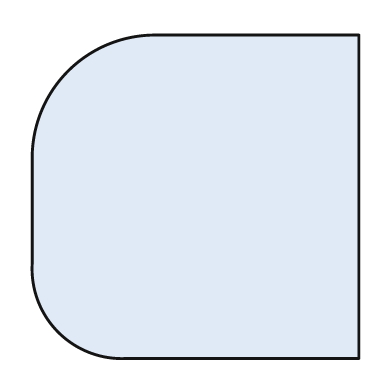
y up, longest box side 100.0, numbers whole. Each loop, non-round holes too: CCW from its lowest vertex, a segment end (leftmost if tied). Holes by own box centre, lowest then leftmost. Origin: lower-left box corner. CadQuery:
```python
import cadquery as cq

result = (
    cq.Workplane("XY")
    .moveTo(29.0, 0.0)
    .lineTo(100.0, 0.0)
    .lineTo(100.0, 99.0)
    .lineTo(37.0, 99.0)
    .threePointArc((11.0, 88.0), (0.0, 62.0))
    .lineTo(0.0, 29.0)
    .threePointArc((8.0, 8.0), (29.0, 0.0))
    .close()
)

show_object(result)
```